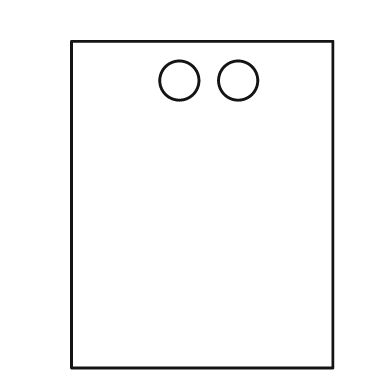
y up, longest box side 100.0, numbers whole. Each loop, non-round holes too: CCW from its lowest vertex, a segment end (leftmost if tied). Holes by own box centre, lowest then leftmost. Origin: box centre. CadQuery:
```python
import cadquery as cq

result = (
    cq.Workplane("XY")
    .moveTo(-40.0, -50.0)
    .lineTo(40.0, -50.0)
    .lineTo(40.0, 50.0)
    .lineTo(-40.0, 50.0)
    .close()
    .moveTo(-7.0, 38.0)
    .circle(6.0)
    .moveTo(11.0, 38.0)
    .circle(6.0)
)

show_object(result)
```